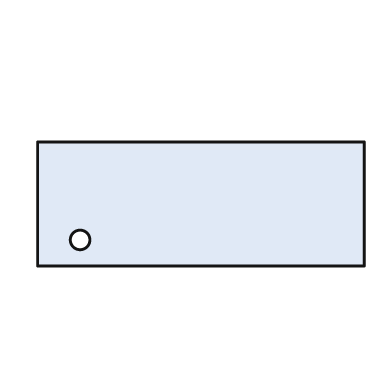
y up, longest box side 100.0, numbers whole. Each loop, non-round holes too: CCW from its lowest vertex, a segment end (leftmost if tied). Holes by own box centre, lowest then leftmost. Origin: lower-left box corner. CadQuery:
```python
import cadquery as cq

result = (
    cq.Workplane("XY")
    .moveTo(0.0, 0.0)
    .lineTo(100.0, 0.0)
    .lineTo(100.0, 38.0)
    .lineTo(0.0, 38.0)
    .close()
    .moveTo(13.0, 8.0)
    .circle(3.0)
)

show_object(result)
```